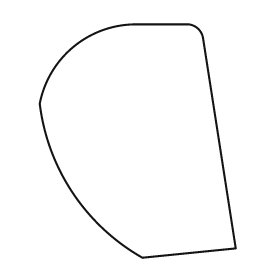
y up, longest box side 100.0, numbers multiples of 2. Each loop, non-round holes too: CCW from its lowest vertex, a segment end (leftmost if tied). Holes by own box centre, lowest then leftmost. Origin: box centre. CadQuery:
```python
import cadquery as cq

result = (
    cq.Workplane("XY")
    .moveTo(2.0, -50.0)
    .lineTo(42.0, -46.0)
    .lineTo(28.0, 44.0)
    .threePointArc((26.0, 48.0), (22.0, 50.0))
    .lineTo(-2.0, 50.0)
    .threePointArc((-28.0, 40.0), (-42.0, 16.0))
    .threePointArc((-28.0, -22.0), (2.0, -50.0))
    .close()
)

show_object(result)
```